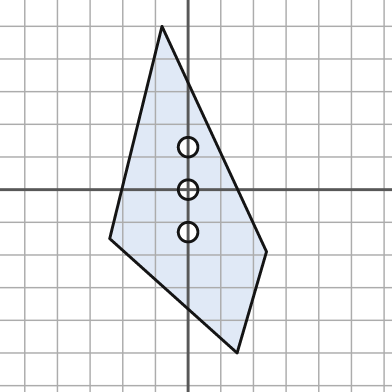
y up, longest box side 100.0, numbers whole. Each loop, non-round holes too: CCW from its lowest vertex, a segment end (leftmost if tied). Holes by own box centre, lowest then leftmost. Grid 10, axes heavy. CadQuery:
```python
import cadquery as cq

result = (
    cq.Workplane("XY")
    .moveTo(15.0, -50.0)
    .lineTo(24.0, -19.0)
    .lineTo(-8.0, 50.0)
    .lineTo(-24.0, -15.0)
    .close()
    .moveTo(0.0, -13.0)
    .circle(3.0)
    .moveTo(0.0, 0.0)
    .circle(3.0)
    .moveTo(0.0, 13.0)
    .circle(3.0)
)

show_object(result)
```